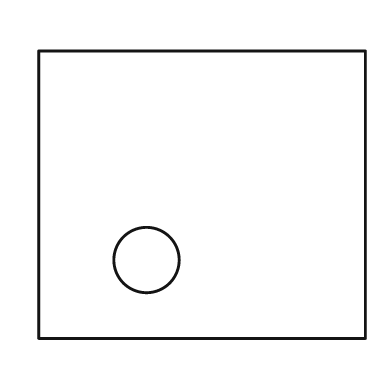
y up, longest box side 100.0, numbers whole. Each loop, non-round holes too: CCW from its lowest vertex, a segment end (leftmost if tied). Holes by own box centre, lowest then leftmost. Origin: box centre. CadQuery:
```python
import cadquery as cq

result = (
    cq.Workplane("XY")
    .moveTo(-50.0, -44.0)
    .lineTo(50.0, -44.0)
    .lineTo(50.0, 44.0)
    .lineTo(-50.0, 44.0)
    .close()
    .moveTo(-17.0, -20.0)
    .circle(10.0)
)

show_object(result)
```